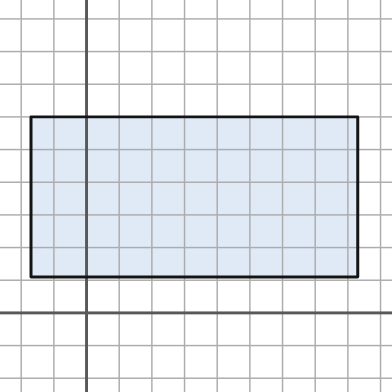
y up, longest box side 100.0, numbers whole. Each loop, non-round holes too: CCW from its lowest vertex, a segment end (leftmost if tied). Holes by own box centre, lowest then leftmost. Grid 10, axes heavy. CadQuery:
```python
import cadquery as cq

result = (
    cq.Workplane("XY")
    .moveTo(-17.0, 11.0)
    .lineTo(83.0, 11.0)
    .lineTo(83.0, 60.0)
    .lineTo(-17.0, 60.0)
    .close()
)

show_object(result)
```